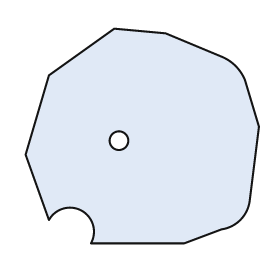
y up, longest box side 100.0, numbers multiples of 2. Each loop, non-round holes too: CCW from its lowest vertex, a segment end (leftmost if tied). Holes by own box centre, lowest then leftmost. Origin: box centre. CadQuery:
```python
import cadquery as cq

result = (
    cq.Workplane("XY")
    .moveTo(-22.0, -46.0)
    .lineTo(18.0, -46.0)
    .lineTo(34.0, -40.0)
    .threePointArc((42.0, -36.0), (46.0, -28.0))
    .lineTo(50.0, 4.0)
    .lineTo(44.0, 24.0)
    .threePointArc((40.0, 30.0), (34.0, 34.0))
    .lineTo(10.0, 44.0)
    .lineTo(-12.0, 46.0)
    .lineTo(-40.0, 26.0)
    .lineTo(-50.0, -8.0)
    .lineTo(-40.0, -36.0)
    .threePointArc((-26.0, -32.0), (-22.0, -46.0))
    .close()
    .moveTo(-10.0, -2.0)
    .circle(4.0)
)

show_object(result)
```